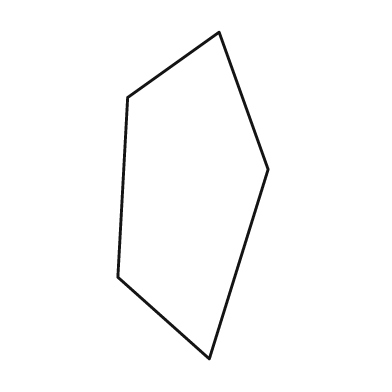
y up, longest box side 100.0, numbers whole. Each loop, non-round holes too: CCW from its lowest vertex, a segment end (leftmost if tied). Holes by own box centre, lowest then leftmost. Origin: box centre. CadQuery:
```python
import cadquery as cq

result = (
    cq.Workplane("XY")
    .moveTo(5.0, -50.0)
    .lineTo(23.0, 8.0)
    .lineTo(8.0, 50.0)
    .lineTo(-20.0, 30.0)
    .lineTo(-23.0, -25.0)
    .close()
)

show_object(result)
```